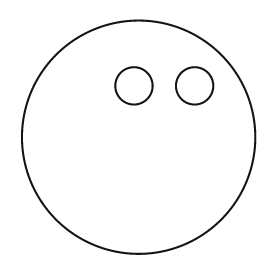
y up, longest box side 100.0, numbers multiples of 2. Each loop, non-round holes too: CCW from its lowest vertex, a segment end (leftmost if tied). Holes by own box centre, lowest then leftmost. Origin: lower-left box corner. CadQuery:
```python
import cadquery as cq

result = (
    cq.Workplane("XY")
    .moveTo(50.0, 50.0)
    .circle(50.0)
    .moveTo(48.0, 72.0)
    .circle(8.0)
    .moveTo(74.0, 72.0)
    .circle(8.0)
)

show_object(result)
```